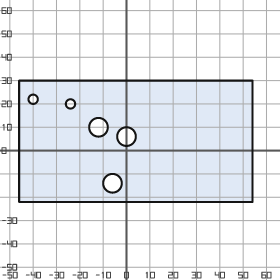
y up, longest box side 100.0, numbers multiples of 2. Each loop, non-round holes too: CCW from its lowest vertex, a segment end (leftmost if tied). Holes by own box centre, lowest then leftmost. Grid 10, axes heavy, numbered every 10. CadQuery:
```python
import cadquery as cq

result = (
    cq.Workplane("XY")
    .moveTo(-46.0, -22.0)
    .lineTo(54.0, -22.0)
    .lineTo(54.0, 30.0)
    .lineTo(-46.0, 30.0)
    .close()
    .moveTo(-6.0, -14.0)
    .circle(4.0)
    .moveTo(0.0, 6.0)
    .circle(4.0)
    .moveTo(-12.0, 10.0)
    .circle(4.0)
    .moveTo(-24.0, 20.0)
    .circle(2.0)
    .moveTo(-40.0, 22.0)
    .circle(2.0)
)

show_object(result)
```